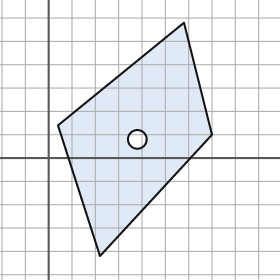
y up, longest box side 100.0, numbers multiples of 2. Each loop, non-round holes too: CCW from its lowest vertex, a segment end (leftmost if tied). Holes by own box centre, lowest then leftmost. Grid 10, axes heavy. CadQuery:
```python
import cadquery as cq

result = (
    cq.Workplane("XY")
    .moveTo(22.0, -42.0)
    .lineTo(70.0, 10.0)
    .lineTo(58.0, 58.0)
    .lineTo(4.0, 14.0)
    .close()
    .moveTo(38.0, 8.0)
    .circle(4.0)
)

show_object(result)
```